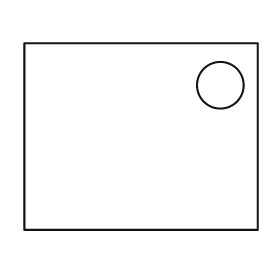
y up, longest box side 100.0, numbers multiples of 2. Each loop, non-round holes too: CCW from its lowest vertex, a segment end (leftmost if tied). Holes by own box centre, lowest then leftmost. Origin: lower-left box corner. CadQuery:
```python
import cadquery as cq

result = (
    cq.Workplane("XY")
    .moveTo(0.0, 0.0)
    .lineTo(100.0, 0.0)
    .lineTo(100.0, 80.0)
    .lineTo(0.0, 80.0)
    .close()
    .moveTo(84.0, 62.0)
    .circle(10.0)
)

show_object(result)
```